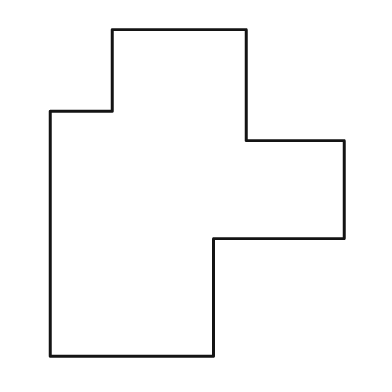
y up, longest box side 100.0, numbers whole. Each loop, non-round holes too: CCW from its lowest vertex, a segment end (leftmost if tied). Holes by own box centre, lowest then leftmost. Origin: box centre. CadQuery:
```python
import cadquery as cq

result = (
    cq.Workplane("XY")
    .moveTo(-45.0, -50.0)
    .lineTo(5.0, -50.0)
    .lineTo(5.0, -14.0)
    .lineTo(45.0, -14.0)
    .lineTo(45.0, 16.0)
    .lineTo(15.0, 16.0)
    .lineTo(15.0, 50.0)
    .lineTo(-26.0, 50.0)
    .lineTo(-26.0, 25.0)
    .lineTo(-45.0, 25.0)
    .close()
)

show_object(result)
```